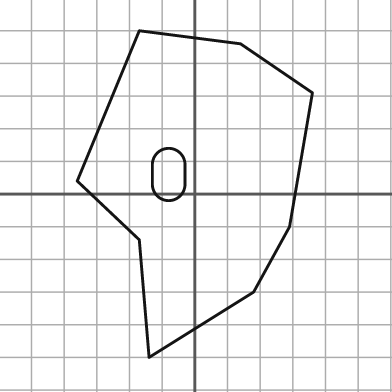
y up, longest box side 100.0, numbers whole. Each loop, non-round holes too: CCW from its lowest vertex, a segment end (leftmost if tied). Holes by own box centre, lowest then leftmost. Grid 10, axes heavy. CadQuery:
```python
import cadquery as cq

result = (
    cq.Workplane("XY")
    .moveTo(-14.0, -50.0)
    .lineTo(18.0, -30.0)
    .lineTo(29.0, -10.0)
    .lineTo(36.0, 31.0)
    .lineTo(14.0, 46.0)
    .lineTo(-17.0, 50.0)
    .lineTo(-36.0, 4.0)
    .lineTo(-17.0, -14.0)
    .close()
    .moveTo(-13.0, 3.0)
    .threePointArc((-8.0, -2.0), (-3.0, 3.0))
    .lineTo(-3.0, 9.0)
    .threePointArc((-8.0, 14.0), (-13.0, 9.0))
    .close()
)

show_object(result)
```